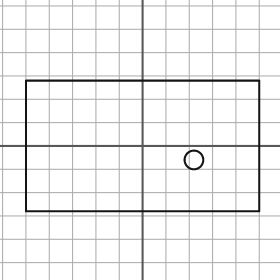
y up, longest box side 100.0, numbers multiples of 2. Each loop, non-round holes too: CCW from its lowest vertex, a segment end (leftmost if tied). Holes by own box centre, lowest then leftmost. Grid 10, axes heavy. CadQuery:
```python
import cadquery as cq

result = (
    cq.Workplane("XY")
    .moveTo(-50.0, -28.0)
    .lineTo(50.0, -28.0)
    .lineTo(50.0, 28.0)
    .lineTo(-50.0, 28.0)
    .close()
    .moveTo(22.0, -6.0)
    .circle(4.0)
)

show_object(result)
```